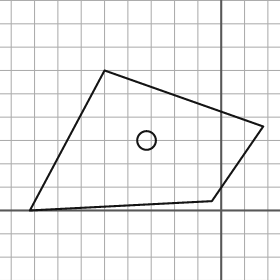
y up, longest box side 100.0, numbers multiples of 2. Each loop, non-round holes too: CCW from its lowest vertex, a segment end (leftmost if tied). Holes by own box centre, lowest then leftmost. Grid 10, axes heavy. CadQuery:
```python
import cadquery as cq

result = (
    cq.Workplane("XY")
    .moveTo(-82.0, 0.0)
    .lineTo(-4.0, 4.0)
    .lineTo(18.0, 36.0)
    .lineTo(-50.0, 60.0)
    .close()
    .moveTo(-32.0, 30.0)
    .circle(4.0)
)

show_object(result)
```